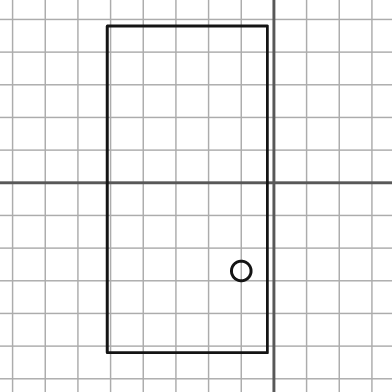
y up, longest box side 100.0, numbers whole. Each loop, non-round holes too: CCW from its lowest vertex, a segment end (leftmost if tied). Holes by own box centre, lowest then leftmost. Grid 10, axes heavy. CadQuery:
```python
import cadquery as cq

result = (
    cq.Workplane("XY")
    .moveTo(-51.0, -52.0)
    .lineTo(-2.0, -52.0)
    .lineTo(-2.0, 48.0)
    .lineTo(-51.0, 48.0)
    .close()
    .moveTo(-10.0, -27.0)
    .circle(3.0)
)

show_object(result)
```